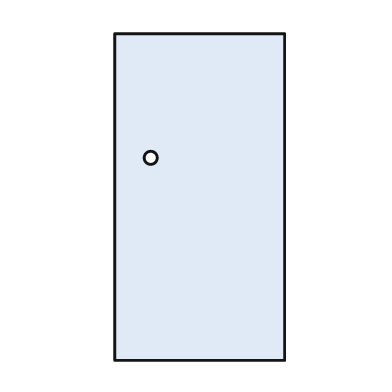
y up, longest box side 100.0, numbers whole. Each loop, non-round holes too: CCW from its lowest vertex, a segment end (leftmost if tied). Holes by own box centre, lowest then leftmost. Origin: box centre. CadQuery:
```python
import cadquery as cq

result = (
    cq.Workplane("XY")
    .moveTo(-26.0, -50.0)
    .lineTo(26.0, -50.0)
    .lineTo(26.0, 50.0)
    .lineTo(-26.0, 50.0)
    .close()
    .moveTo(-15.0, 12.0)
    .circle(2.0)
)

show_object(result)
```